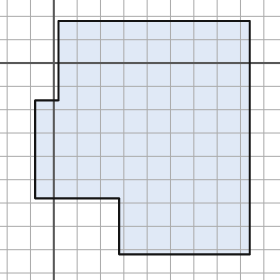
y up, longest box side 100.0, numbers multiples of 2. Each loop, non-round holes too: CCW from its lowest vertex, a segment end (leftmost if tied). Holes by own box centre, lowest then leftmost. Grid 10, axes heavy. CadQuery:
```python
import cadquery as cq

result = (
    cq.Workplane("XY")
    .moveTo(28.0, -82.0)
    .lineTo(84.0, -82.0)
    .lineTo(84.0, 18.0)
    .lineTo(2.0, 18.0)
    .lineTo(2.0, -16.0)
    .lineTo(-8.0, -16.0)
    .lineTo(-8.0, -58.0)
    .lineTo(28.0, -58.0)
    .close()
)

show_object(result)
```